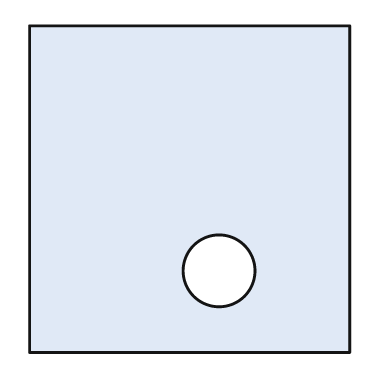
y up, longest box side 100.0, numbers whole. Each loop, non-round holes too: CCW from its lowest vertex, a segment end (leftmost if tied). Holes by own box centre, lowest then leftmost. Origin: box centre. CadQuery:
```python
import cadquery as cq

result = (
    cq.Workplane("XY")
    .moveTo(-49.0, -50.0)
    .lineTo(49.0, -50.0)
    .lineTo(49.0, 50.0)
    .lineTo(-49.0, 50.0)
    .close()
    .moveTo(9.0, -25.0)
    .circle(11.0)
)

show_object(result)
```